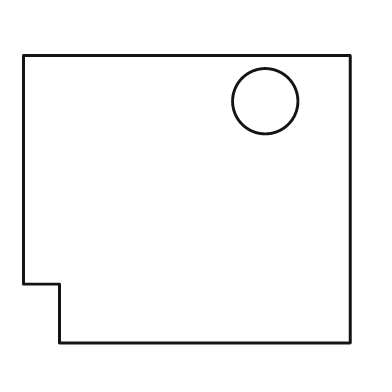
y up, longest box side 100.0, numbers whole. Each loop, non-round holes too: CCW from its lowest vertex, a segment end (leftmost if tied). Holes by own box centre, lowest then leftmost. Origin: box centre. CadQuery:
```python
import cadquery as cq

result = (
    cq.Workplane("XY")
    .moveTo(-39.0, -44.0)
    .lineTo(50.0, -44.0)
    .lineTo(50.0, 44.0)
    .lineTo(-50.0, 44.0)
    .lineTo(-50.0, -26.0)
    .lineTo(-39.0, -26.0)
    .close()
    .moveTo(24.0, 30.0)
    .circle(10.0)
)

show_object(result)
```